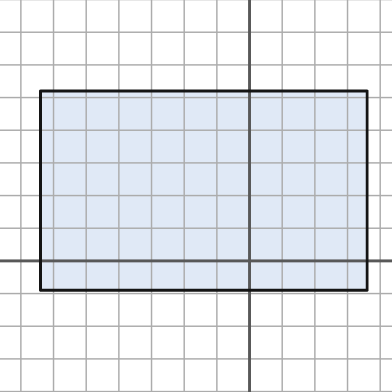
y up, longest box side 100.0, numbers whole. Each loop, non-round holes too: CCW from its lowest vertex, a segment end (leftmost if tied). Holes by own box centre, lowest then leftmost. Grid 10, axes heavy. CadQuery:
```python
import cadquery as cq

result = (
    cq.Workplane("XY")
    .moveTo(-64.0, -9.0)
    .lineTo(36.0, -9.0)
    .lineTo(36.0, 52.0)
    .lineTo(-64.0, 52.0)
    .close()
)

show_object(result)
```